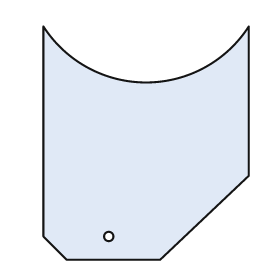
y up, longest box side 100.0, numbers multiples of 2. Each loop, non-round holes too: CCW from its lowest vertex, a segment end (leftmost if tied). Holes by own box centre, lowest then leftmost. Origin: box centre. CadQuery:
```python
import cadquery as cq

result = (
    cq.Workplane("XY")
    .moveTo(-34.0, -50.0)
    .lineTo(6.0, -50.0)
    .lineTo(44.0, -14.0)
    .lineTo(44.0, 50.0)
    .threePointArc((0.0, 26.0), (-44.0, 50.0))
    .lineTo(-44.0, -40.0)
    .close()
    .moveTo(-16.0, -40.0)
    .circle(2.0)
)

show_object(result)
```